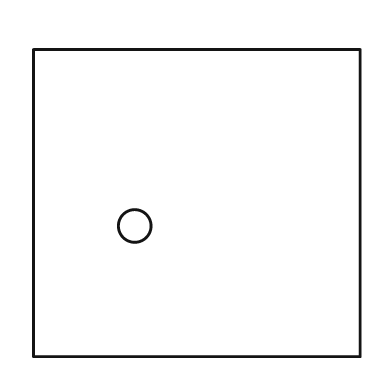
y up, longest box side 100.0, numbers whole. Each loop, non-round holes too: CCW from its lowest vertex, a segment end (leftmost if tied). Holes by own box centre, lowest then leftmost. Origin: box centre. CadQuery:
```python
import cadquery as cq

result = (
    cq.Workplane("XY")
    .moveTo(-50.0, -47.0)
    .lineTo(50.0, -47.0)
    .lineTo(50.0, 47.0)
    .lineTo(-50.0, 47.0)
    .close()
    .moveTo(-19.0, -7.0)
    .circle(5.0)
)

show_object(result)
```